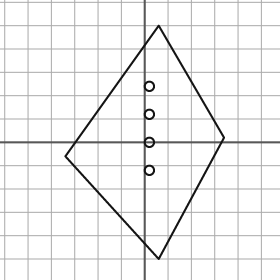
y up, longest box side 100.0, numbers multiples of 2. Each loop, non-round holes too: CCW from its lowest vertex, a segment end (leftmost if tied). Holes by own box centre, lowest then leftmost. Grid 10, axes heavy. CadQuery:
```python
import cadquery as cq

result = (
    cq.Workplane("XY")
    .moveTo(6.0, -50.0)
    .lineTo(34.0, 2.0)
    .lineTo(6.0, 50.0)
    .lineTo(-34.0, -6.0)
    .close()
    .moveTo(2.0, -12.0)
    .circle(2.0)
    .moveTo(2.0, 0.0)
    .circle(2.0)
    .moveTo(2.0, 12.0)
    .circle(2.0)
    .moveTo(2.0, 24.0)
    .circle(2.0)
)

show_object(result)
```